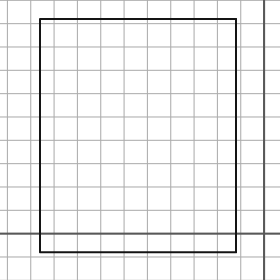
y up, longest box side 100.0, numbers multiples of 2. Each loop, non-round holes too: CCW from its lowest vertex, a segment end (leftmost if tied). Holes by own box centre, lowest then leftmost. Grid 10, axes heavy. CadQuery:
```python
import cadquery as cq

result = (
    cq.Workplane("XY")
    .moveTo(-96.0, -8.0)
    .lineTo(-12.0, -8.0)
    .lineTo(-12.0, 92.0)
    .lineTo(-96.0, 92.0)
    .close()
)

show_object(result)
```